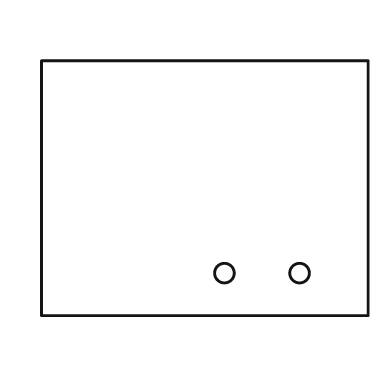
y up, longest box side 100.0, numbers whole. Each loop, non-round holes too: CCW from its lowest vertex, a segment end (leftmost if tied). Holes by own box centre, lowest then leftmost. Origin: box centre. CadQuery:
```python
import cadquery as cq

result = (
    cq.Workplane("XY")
    .moveTo(-50.0, -39.0)
    .lineTo(50.0, -39.0)
    .lineTo(50.0, 39.0)
    .lineTo(-50.0, 39.0)
    .close()
    .moveTo(6.0, -26.0)
    .circle(3.0)
    .moveTo(29.0, -26.0)
    .circle(3.0)
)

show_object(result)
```